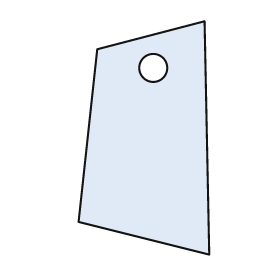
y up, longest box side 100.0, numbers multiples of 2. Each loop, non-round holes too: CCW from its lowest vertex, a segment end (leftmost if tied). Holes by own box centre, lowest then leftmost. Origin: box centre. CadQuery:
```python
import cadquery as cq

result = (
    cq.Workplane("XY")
    .moveTo(28.0, -50.0)
    .lineTo(26.0, 50.0)
    .lineTo(-20.0, 38.0)
    .lineTo(-28.0, -36.0)
    .close()
    .moveTo(4.0, 30.0)
    .circle(6.0)
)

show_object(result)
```